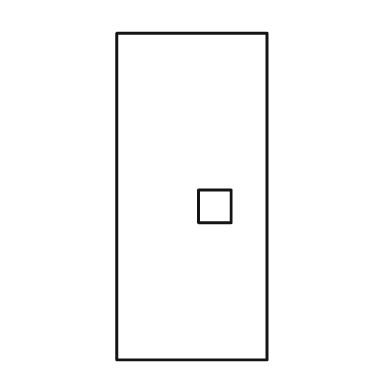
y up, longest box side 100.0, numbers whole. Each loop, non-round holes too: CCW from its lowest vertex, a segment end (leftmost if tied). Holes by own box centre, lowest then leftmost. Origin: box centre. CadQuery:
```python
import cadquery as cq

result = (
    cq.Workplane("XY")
    .moveTo(-23.0, -50.0)
    .lineTo(23.0, -50.0)
    .lineTo(23.0, 50.0)
    .lineTo(-23.0, 50.0)
    .close()
    .moveTo(2.0, -8.0)
    .lineTo(12.0, -8.0)
    .lineTo(12.0, 2.0)
    .lineTo(2.0, 2.0)
    .close()
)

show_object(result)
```